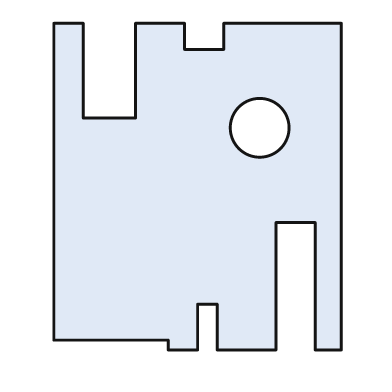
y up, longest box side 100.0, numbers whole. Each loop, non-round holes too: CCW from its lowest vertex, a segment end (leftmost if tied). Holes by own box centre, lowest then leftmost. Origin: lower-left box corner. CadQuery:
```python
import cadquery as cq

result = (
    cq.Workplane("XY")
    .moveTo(35.0, 0.0)
    .lineTo(44.0, 0.0)
    .lineTo(44.0, 14.0)
    .lineTo(50.0, 14.0)
    .lineTo(50.0, 0.0)
    .lineTo(68.0, 0.0)
    .lineTo(68.0, 39.0)
    .lineTo(80.0, 39.0)
    .lineTo(80.0, 0.0)
    .lineTo(88.0, 0.0)
    .lineTo(88.0, 100.0)
    .lineTo(52.0, 100.0)
    .lineTo(52.0, 92.0)
    .lineTo(40.0, 92.0)
    .lineTo(40.0, 100.0)
    .lineTo(25.0, 100.0)
    .lineTo(25.0, 71.0)
    .lineTo(9.0, 71.0)
    .lineTo(9.0, 100.0)
    .lineTo(0.0, 100.0)
    .lineTo(0.0, 3.0)
    .lineTo(35.0, 3.0)
    .close()
    .moveTo(63.0, 68.0)
    .circle(9.0)
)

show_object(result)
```